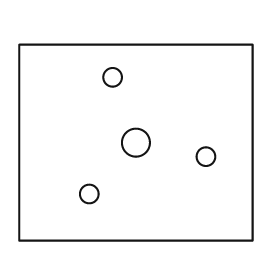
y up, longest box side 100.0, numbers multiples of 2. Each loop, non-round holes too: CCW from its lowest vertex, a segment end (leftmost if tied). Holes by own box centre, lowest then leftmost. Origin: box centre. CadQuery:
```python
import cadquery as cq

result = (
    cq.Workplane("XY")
    .moveTo(-50.0, -42.0)
    .lineTo(50.0, -42.0)
    .lineTo(50.0, 42.0)
    .lineTo(-50.0, 42.0)
    .close()
    .moveTo(-20.0, -22.0)
    .circle(4.0)
    .moveTo(30.0, -6.0)
    .circle(4.0)
    .moveTo(0.0, 0.0)
    .circle(6.0)
    .moveTo(-10.0, 28.0)
    .circle(4.0)
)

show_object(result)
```